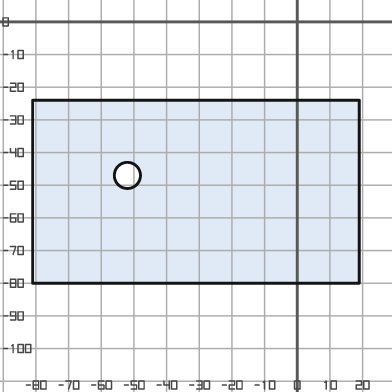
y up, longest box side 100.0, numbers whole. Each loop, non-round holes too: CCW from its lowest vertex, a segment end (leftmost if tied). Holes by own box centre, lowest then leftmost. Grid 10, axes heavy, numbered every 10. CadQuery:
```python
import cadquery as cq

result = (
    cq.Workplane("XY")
    .moveTo(-81.0, -80.0)
    .lineTo(19.0, -80.0)
    .lineTo(19.0, -24.0)
    .lineTo(-81.0, -24.0)
    .close()
    .moveTo(-52.0, -47.0)
    .circle(4.0)
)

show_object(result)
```